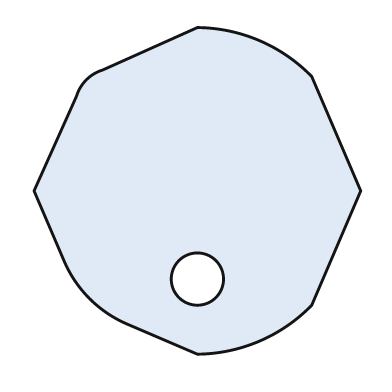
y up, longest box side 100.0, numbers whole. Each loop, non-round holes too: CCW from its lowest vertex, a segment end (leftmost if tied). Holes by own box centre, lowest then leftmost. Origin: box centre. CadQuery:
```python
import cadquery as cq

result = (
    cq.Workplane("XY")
    .moveTo(0.0, -50.0)
    .threePointArc((19.0, -46.0), (35.0, -35.0))
    .lineTo(50.0, 0.0)
    .lineTo(35.0, 35.0)
    .threePointArc((19.0, 46.0), (0.0, 50.0))
    .lineTo(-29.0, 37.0)
    .threePointArc((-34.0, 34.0), (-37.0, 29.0))
    .lineTo(-50.0, 0.0)
    .lineTo(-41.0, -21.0)
    .threePointArc((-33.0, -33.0), (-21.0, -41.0))
    .close()
    .moveTo(0.0, -27.0)
    .circle(8.0)
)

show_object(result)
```